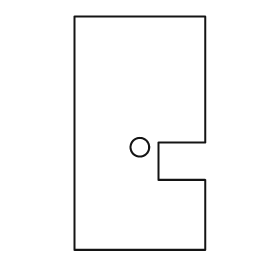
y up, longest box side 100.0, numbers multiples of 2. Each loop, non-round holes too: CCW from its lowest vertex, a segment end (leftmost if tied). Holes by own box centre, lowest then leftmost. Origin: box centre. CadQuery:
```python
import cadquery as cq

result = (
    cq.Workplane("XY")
    .moveTo(-28.0, -50.0)
    .lineTo(28.0, -50.0)
    .lineTo(28.0, -20.0)
    .lineTo(8.0, -20.0)
    .lineTo(8.0, -4.0)
    .lineTo(28.0, -4.0)
    .lineTo(28.0, 50.0)
    .lineTo(-28.0, 50.0)
    .close()
    .moveTo(0.0, -6.0)
    .circle(4.0)
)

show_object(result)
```